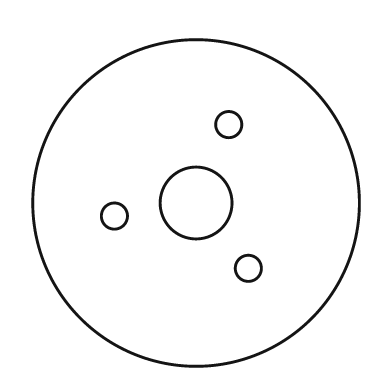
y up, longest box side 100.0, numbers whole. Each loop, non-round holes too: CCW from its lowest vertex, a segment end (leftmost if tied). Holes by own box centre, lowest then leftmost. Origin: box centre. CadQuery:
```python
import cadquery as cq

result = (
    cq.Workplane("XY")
    .moveTo(0.0, 0.0)
    .circle(50.0)
    .moveTo(16.0, -20.0)
    .circle(4.0)
    .moveTo(-25.0, -4.0)
    .circle(4.0)
    .moveTo(0.0, 0.0)
    .circle(11.0)
    .moveTo(10.0, 24.0)
    .circle(4.0)
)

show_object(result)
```